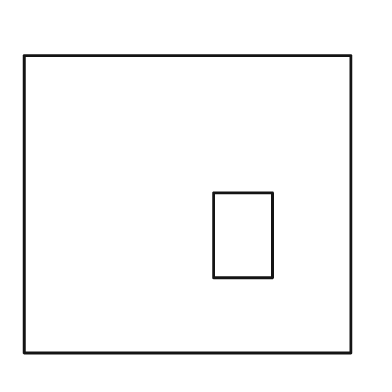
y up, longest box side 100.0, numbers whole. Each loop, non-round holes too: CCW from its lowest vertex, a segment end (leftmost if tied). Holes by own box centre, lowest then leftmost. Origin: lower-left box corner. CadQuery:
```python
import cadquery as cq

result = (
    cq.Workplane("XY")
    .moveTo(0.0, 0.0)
    .lineTo(100.0, 0.0)
    .lineTo(100.0, 91.0)
    .lineTo(0.0, 91.0)
    .close()
    .moveTo(58.0, 23.0)
    .lineTo(76.0, 23.0)
    .lineTo(76.0, 49.0)
    .lineTo(58.0, 49.0)
    .close()
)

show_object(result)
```